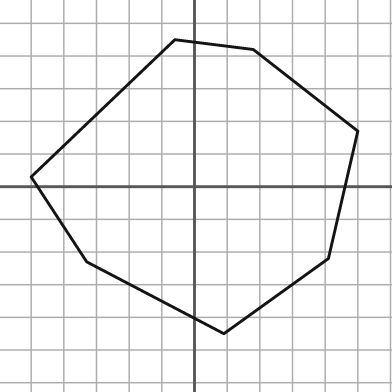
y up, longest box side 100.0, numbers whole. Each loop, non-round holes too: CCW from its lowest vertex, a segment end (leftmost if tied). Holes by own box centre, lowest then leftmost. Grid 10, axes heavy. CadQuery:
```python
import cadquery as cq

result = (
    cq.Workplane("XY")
    .moveTo(9.0, -45.0)
    .lineTo(41.0, -22.0)
    .lineTo(50.0, 17.0)
    .lineTo(18.0, 42.0)
    .lineTo(-6.0, 45.0)
    .lineTo(-50.0, 3.0)
    .lineTo(-33.0, -23.0)
    .close()
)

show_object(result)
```